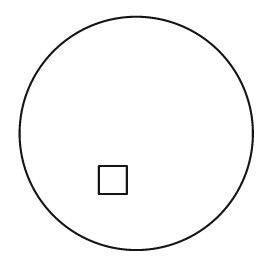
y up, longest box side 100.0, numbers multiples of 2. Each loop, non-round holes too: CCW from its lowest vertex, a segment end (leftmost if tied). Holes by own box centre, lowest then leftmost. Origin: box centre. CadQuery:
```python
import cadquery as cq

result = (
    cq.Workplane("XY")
    .moveTo(0.0, 0.0)
    .circle(50.0)
    .moveTo(-16.0, -26.0)
    .lineTo(-4.0, -26.0)
    .lineTo(-4.0, -14.0)
    .lineTo(-16.0, -14.0)
    .close()
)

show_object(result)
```